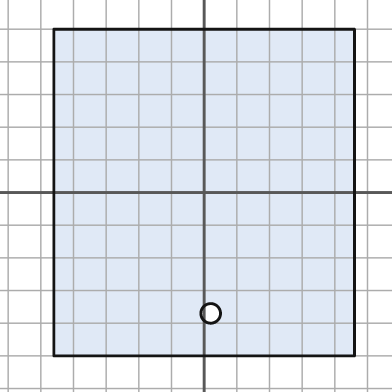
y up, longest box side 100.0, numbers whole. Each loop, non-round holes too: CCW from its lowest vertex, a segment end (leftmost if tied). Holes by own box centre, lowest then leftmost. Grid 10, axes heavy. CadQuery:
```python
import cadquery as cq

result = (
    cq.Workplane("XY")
    .moveTo(-46.0, -50.0)
    .lineTo(46.0, -50.0)
    .lineTo(46.0, 50.0)
    .lineTo(-46.0, 50.0)
    .close()
    .moveTo(2.0, -37.0)
    .circle(3.0)
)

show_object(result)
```